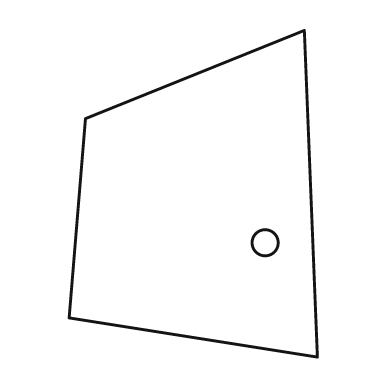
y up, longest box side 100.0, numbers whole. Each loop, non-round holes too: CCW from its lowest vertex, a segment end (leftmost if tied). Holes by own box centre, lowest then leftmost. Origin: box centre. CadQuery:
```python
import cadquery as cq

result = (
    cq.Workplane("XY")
    .moveTo(38.0, -50.0)
    .lineTo(34.0, 50.0)
    .lineTo(-33.0, 23.0)
    .lineTo(-38.0, -38.0)
    .close()
    .moveTo(22.0, -15.0)
    .circle(4.0)
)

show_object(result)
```